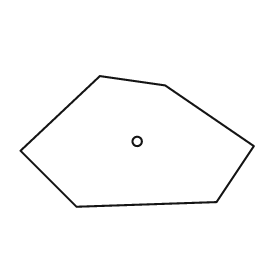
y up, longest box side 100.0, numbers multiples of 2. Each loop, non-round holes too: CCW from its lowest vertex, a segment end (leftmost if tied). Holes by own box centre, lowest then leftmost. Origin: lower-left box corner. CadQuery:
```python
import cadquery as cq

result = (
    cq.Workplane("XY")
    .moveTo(24.0, 0.0)
    .lineTo(84.0, 2.0)
    .lineTo(100.0, 26.0)
    .lineTo(62.0, 52.0)
    .lineTo(34.0, 56.0)
    .lineTo(0.0, 24.0)
    .close()
    .moveTo(50.0, 28.0)
    .circle(2.0)
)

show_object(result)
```